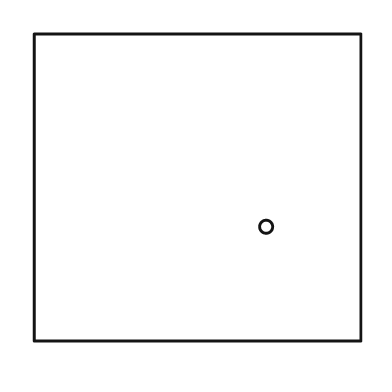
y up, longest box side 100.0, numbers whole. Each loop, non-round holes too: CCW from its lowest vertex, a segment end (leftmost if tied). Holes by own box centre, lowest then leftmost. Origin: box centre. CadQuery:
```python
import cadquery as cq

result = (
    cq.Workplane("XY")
    .moveTo(-50.0, -47.0)
    .lineTo(50.0, -47.0)
    .lineTo(50.0, 47.0)
    .lineTo(-50.0, 47.0)
    .close()
    .moveTo(21.0, -12.0)
    .circle(2.0)
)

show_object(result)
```